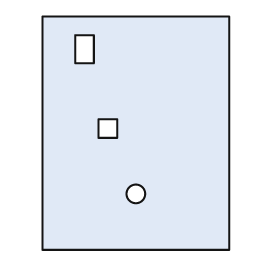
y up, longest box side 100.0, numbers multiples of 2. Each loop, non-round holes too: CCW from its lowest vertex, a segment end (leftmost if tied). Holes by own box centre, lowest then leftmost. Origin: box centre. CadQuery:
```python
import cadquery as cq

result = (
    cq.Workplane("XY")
    .moveTo(-40.0, -50.0)
    .lineTo(40.0, -50.0)
    .lineTo(40.0, 50.0)
    .lineTo(-40.0, 50.0)
    .close()
    .moveTo(0.0, -26.0)
    .circle(4.0)
    .moveTo(-16.0, -2.0)
    .lineTo(-8.0, -2.0)
    .lineTo(-8.0, 6.0)
    .lineTo(-16.0, 6.0)
    .close()
    .moveTo(-26.0, 30.0)
    .lineTo(-18.0, 30.0)
    .lineTo(-18.0, 42.0)
    .lineTo(-26.0, 42.0)
    .close()
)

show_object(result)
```